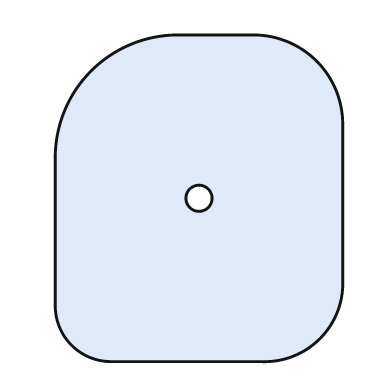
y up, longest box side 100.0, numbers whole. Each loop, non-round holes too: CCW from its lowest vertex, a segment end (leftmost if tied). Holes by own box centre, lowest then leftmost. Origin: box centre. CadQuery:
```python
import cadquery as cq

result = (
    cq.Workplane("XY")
    .moveTo(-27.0, -50.0)
    .lineTo(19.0, -50.0)
    .threePointArc((37.0, -43.0), (44.0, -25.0))
    .lineTo(44.0, 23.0)
    .threePointArc((36.0, 42.0), (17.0, 50.0))
    .lineTo(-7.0, 50.0)
    .threePointArc((-33.0, 39.0), (-44.0, 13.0))
    .lineTo(-44.0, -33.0)
    .threePointArc((-39.0, -45.0), (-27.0, -50.0))
    .close()
    .moveTo(0.0, 0.0)
    .circle(4.0)
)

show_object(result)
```